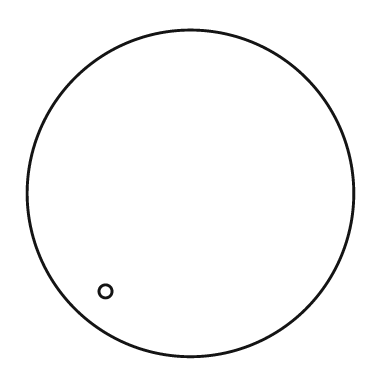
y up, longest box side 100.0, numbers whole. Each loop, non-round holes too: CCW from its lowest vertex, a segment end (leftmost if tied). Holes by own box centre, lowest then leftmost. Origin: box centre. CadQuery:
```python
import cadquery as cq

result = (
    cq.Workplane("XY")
    .moveTo(0.0, 0.0)
    .circle(50.0)
    .moveTo(-26.0, -30.0)
    .circle(2.0)
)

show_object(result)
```